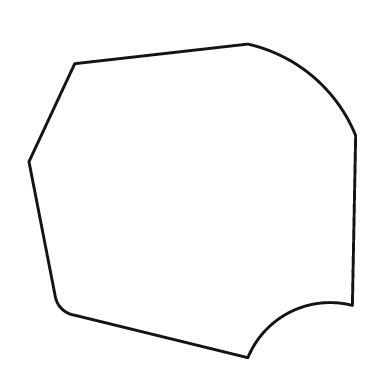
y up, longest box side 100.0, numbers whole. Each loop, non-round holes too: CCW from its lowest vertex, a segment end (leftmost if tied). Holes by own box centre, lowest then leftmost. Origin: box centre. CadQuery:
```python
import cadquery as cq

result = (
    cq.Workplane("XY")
    .moveTo(17.0, -48.0)
    .threePointArc((30.0, -34.0), (49.0, -32.0))
    .lineTo(50.0, 20.0)
    .threePointArc((37.0, 38.0), (17.0, 48.0))
    .lineTo(-36.0, 42.0)
    .lineTo(-50.0, 12.0)
    .lineTo(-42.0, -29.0)
    .threePointArc((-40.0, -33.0), (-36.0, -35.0))
    .close()
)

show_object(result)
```